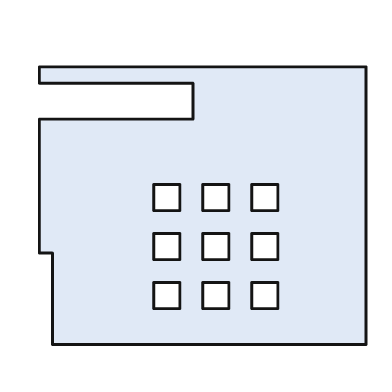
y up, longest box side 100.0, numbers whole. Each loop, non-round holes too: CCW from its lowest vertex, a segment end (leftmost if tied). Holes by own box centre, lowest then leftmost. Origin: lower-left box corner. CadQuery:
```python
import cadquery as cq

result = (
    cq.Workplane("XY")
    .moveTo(4.0, 0.0)
    .lineTo(100.0, 0.0)
    .lineTo(100.0, 85.0)
    .lineTo(0.0, 85.0)
    .lineTo(0.0, 80.0)
    .lineTo(47.0, 80.0)
    .lineTo(47.0, 69.0)
    .lineTo(0.0, 69.0)
    .lineTo(0.0, 28.0)
    .lineTo(4.0, 28.0)
    .close()
    .moveTo(35.0, 11.0)
    .lineTo(43.0, 11.0)
    .lineTo(43.0, 19.0)
    .lineTo(35.0, 19.0)
    .close()
    .moveTo(50.0, 11.0)
    .lineTo(58.0, 11.0)
    .lineTo(58.0, 19.0)
    .lineTo(50.0, 19.0)
    .close()
    .moveTo(65.0, 11.0)
    .lineTo(73.0, 11.0)
    .lineTo(73.0, 19.0)
    .lineTo(65.0, 19.0)
    .close()
    .moveTo(35.0, 26.0)
    .lineTo(43.0, 26.0)
    .lineTo(43.0, 34.0)
    .lineTo(35.0, 34.0)
    .close()
    .moveTo(50.0, 26.0)
    .lineTo(58.0, 26.0)
    .lineTo(58.0, 34.0)
    .lineTo(50.0, 34.0)
    .close()
    .moveTo(65.0, 26.0)
    .lineTo(73.0, 26.0)
    .lineTo(73.0, 34.0)
    .lineTo(65.0, 34.0)
    .close()
    .moveTo(35.0, 41.0)
    .lineTo(43.0, 41.0)
    .lineTo(43.0, 49.0)
    .lineTo(35.0, 49.0)
    .close()
    .moveTo(50.0, 41.0)
    .lineTo(58.0, 41.0)
    .lineTo(58.0, 49.0)
    .lineTo(50.0, 49.0)
    .close()
    .moveTo(65.0, 41.0)
    .lineTo(73.0, 41.0)
    .lineTo(73.0, 49.0)
    .lineTo(65.0, 49.0)
    .close()
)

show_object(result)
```